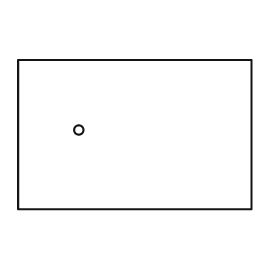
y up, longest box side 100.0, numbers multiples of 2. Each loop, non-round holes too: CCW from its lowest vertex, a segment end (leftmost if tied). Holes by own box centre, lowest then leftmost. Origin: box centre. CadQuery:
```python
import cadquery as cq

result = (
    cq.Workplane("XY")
    .moveTo(-50.0, -32.0)
    .lineTo(50.0, -32.0)
    .lineTo(50.0, 32.0)
    .lineTo(-50.0, 32.0)
    .close()
    .moveTo(-24.0, 2.0)
    .circle(2.0)
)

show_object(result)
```